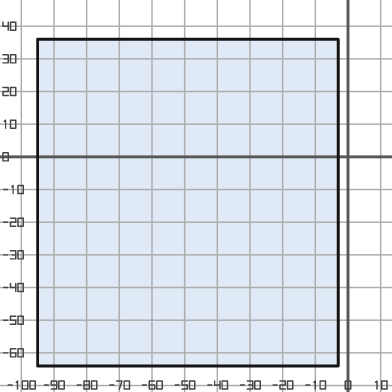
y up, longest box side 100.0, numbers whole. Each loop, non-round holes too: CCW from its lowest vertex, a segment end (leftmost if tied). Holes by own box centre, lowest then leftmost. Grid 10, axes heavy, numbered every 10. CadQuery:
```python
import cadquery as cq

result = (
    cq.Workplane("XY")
    .moveTo(-95.0, -64.0)
    .lineTo(-3.0, -64.0)
    .lineTo(-3.0, 36.0)
    .lineTo(-95.0, 36.0)
    .close()
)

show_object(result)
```